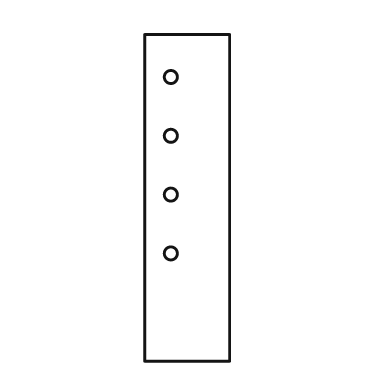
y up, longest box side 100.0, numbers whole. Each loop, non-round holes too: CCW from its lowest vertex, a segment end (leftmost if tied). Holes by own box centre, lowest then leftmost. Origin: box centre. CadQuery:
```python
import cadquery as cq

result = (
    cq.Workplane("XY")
    .moveTo(-13.0, -50.0)
    .lineTo(13.0, -50.0)
    .lineTo(13.0, 50.0)
    .lineTo(-13.0, 50.0)
    .close()
    .moveTo(-5.0, -17.0)
    .circle(2.0)
    .moveTo(-5.0, 1.0)
    .circle(2.0)
    .moveTo(-5.0, 19.0)
    .circle(2.0)
    .moveTo(-5.0, 37.0)
    .circle(2.0)
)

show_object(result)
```